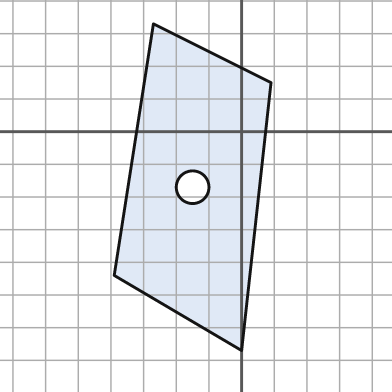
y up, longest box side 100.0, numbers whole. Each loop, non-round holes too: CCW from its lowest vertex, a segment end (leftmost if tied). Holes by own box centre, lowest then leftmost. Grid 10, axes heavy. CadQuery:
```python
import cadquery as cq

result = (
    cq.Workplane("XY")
    .moveTo(0.0, -67.0)
    .lineTo(9.0, 15.0)
    .lineTo(-27.0, 33.0)
    .lineTo(-39.0, -44.0)
    .close()
    .moveTo(-15.0, -17.0)
    .circle(5.0)
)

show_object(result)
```